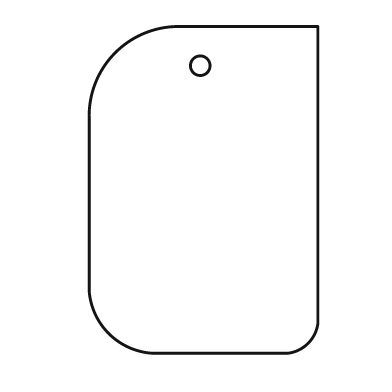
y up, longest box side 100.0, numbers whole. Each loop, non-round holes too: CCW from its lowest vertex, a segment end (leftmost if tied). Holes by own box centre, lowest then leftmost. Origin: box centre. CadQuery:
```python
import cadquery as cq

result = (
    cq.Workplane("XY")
    .moveTo(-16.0, -50.0)
    .lineTo(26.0, -50.0)
    .threePointArc((32.0, -47.0), (35.0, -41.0))
    .lineTo(35.0, 50.0)
    .lineTo(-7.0, 50.0)
    .threePointArc((-27.0, 42.0), (-35.0, 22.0))
    .lineTo(-35.0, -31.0)
    .threePointArc((-29.0, -44.0), (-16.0, -50.0))
    .close()
    .moveTo(-1.0, 38.0)
    .circle(3.0)
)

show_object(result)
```